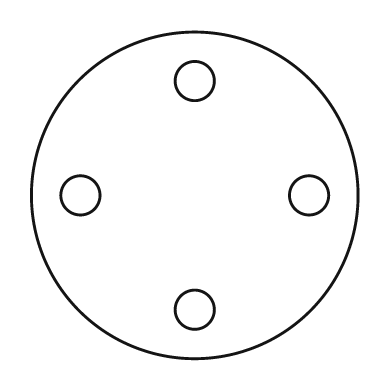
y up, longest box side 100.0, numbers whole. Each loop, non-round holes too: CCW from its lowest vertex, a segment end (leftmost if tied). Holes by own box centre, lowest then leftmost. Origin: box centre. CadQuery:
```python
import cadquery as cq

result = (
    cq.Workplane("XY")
    .moveTo(0.0, 0.0)
    .circle(50.0)
    .moveTo(0.0, -35.0)
    .circle(6.0)
    .moveTo(-35.0, 0.0)
    .circle(6.0)
    .moveTo(35.0, 0.0)
    .circle(6.0)
    .moveTo(0.0, 35.0)
    .circle(6.0)
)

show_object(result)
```